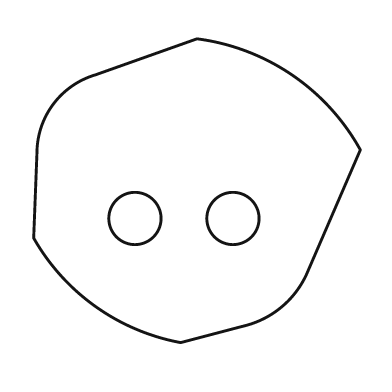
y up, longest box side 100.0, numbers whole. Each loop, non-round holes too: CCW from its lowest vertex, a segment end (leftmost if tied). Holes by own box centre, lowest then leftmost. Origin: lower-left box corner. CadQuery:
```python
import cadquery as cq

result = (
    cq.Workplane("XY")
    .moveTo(45.0, 0.0)
    .lineTo(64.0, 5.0)
    .threePointArc((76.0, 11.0), (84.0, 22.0))
    .lineTo(100.0, 59.0)
    .threePointArc((79.0, 82.0), (50.0, 93.0))
    .lineTo(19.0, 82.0)
    .threePointArc((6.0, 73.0), (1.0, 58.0))
    .lineTo(0.0, 32.0)
    .threePointArc((19.0, 11.0), (45.0, 0.0))
    .close()
    .moveTo(31.0, 38.0)
    .circle(8.0)
    .moveTo(61.0, 38.0)
    .circle(8.0)
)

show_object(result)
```